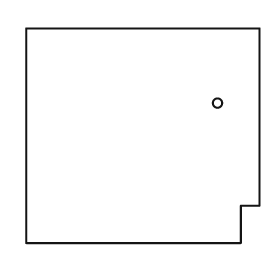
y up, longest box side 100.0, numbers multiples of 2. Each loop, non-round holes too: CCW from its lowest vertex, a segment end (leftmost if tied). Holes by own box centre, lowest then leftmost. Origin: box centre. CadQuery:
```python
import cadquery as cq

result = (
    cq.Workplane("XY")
    .moveTo(-50.0, -46.0)
    .lineTo(42.0, -46.0)
    .lineTo(42.0, -30.0)
    .lineTo(50.0, -30.0)
    .lineTo(50.0, 46.0)
    .lineTo(-50.0, 46.0)
    .close()
    .moveTo(32.0, 14.0)
    .circle(2.0)
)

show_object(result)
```